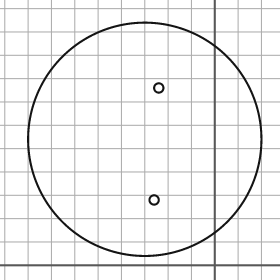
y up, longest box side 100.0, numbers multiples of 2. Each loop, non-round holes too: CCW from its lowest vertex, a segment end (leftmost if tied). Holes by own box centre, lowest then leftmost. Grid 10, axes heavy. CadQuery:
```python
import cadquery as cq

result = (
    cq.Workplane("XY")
    .moveTo(-30.0, 54.0)
    .circle(50.0)
    .moveTo(-26.0, 28.0)
    .circle(2.0)
    .moveTo(-24.0, 76.0)
    .circle(2.0)
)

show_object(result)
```